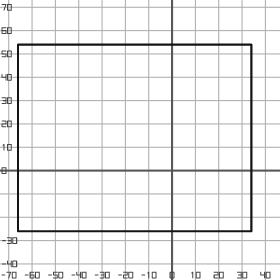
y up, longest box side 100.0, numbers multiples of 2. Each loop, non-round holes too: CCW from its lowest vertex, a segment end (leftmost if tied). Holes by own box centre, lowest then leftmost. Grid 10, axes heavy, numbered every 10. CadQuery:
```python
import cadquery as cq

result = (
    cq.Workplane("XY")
    .moveTo(-66.0, -26.0)
    .lineTo(34.0, -26.0)
    .lineTo(34.0, 54.0)
    .lineTo(-66.0, 54.0)
    .close()
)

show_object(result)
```